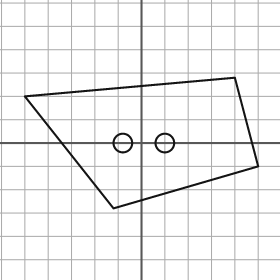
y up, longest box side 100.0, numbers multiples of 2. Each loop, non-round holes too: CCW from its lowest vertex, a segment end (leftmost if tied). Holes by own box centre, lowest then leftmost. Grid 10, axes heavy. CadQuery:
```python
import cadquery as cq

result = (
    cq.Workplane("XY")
    .moveTo(-12.0, -28.0)
    .lineTo(50.0, -10.0)
    .lineTo(40.0, 28.0)
    .lineTo(-50.0, 20.0)
    .close()
    .moveTo(-8.0, 0.0)
    .circle(4.0)
    .moveTo(10.0, 0.0)
    .circle(4.0)
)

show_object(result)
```